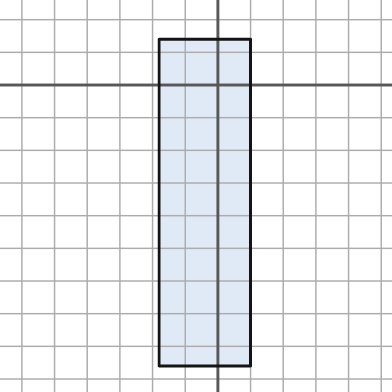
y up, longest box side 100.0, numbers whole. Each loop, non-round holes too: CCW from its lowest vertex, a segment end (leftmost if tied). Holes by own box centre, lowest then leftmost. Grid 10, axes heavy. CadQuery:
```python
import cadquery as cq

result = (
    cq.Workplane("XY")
    .moveTo(-18.0, -86.0)
    .lineTo(10.0, -86.0)
    .lineTo(10.0, 14.0)
    .lineTo(-18.0, 14.0)
    .close()
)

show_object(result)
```